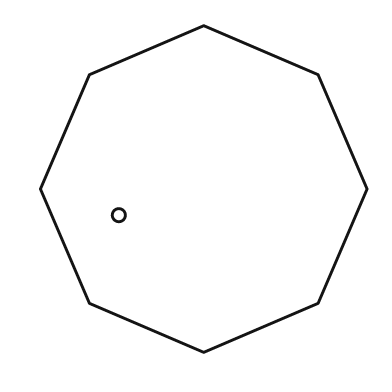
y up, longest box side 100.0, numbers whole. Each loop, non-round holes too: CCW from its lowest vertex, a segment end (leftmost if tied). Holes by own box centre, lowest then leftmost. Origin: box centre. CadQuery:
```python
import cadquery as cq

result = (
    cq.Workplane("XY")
    .moveTo(0.0, -50.0)
    .lineTo(35.0, -35.0)
    .lineTo(50.0, 0.0)
    .lineTo(35.0, 35.0)
    .lineTo(0.0, 50.0)
    .lineTo(-35.0, 35.0)
    .lineTo(-50.0, 0.0)
    .lineTo(-35.0, -35.0)
    .close()
    .moveTo(-26.0, -8.0)
    .circle(2.0)
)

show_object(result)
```